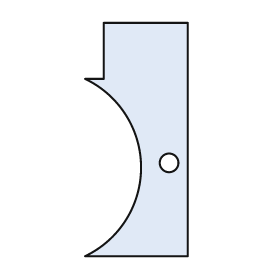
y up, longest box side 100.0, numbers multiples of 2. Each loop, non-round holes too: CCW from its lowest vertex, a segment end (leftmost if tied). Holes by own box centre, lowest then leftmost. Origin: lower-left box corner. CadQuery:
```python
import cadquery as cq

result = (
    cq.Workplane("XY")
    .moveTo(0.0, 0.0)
    .lineTo(44.0, 0.0)
    .lineTo(44.0, 100.0)
    .lineTo(8.0, 100.0)
    .lineTo(8.0, 76.0)
    .lineTo(0.0, 76.0)
    .threePointArc((24.0, 38.0), (0.0, 0.0))
    .close()
    .moveTo(36.0, 40.0)
    .circle(4.0)
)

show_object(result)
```